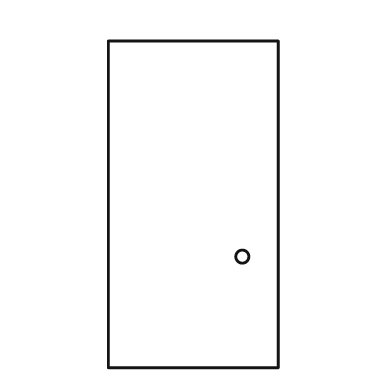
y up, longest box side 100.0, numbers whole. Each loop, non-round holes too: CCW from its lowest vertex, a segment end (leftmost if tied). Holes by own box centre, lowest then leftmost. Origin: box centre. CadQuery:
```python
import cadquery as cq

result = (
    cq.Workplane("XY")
    .moveTo(-26.0, -50.0)
    .lineTo(26.0, -50.0)
    .lineTo(26.0, 50.0)
    .lineTo(-26.0, 50.0)
    .close()
    .moveTo(15.0, -16.0)
    .circle(2.0)
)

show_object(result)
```